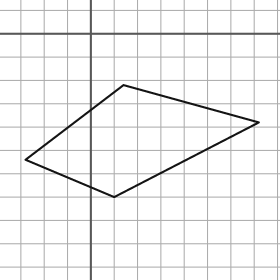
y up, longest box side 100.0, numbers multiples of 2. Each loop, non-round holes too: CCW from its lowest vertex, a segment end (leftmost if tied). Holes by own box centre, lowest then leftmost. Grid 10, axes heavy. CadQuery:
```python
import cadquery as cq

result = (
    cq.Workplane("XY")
    .moveTo(10.0, -70.0)
    .lineTo(72.0, -38.0)
    .lineTo(14.0, -22.0)
    .lineTo(-28.0, -54.0)
    .close()
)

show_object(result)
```